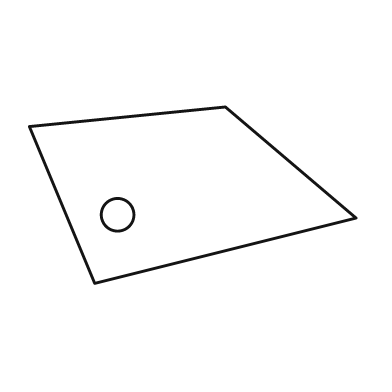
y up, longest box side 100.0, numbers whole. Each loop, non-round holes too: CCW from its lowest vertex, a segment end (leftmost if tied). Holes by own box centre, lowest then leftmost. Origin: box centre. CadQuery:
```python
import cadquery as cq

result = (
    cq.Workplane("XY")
    .moveTo(-30.0, -27.0)
    .lineTo(50.0, -7.0)
    .lineTo(10.0, 27.0)
    .lineTo(-50.0, 21.0)
    .close()
    .moveTo(-23.0, -6.0)
    .circle(5.0)
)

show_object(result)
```